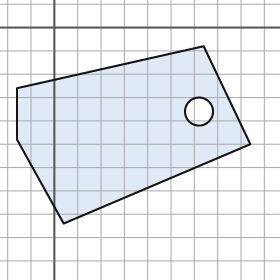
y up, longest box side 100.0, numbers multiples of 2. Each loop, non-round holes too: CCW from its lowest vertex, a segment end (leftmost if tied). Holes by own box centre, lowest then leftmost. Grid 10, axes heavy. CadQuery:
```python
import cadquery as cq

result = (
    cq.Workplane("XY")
    .moveTo(4.0, -84.0)
    .lineTo(84.0, -50.0)
    .lineTo(64.0, -8.0)
    .lineTo(-16.0, -26.0)
    .lineTo(-16.0, -48.0)
    .close()
    .moveTo(62.0, -36.0)
    .circle(6.0)
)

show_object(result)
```